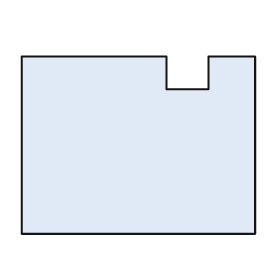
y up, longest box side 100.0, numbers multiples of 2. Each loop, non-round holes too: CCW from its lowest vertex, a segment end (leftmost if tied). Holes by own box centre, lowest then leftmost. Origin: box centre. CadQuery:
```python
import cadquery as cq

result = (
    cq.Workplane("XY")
    .moveTo(-50.0, -38.0)
    .lineTo(50.0, -38.0)
    .lineTo(50.0, 38.0)
    .lineTo(30.0, 38.0)
    .lineTo(30.0, 24.0)
    .lineTo(12.0, 24.0)
    .lineTo(12.0, 38.0)
    .lineTo(-50.0, 38.0)
    .close()
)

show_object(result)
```